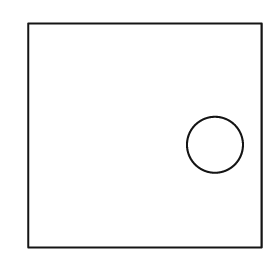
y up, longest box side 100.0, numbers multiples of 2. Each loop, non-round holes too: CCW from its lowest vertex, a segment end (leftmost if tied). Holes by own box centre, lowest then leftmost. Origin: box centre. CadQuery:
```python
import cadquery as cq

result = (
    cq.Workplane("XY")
    .moveTo(-50.0, -48.0)
    .lineTo(50.0, -48.0)
    .lineTo(50.0, 48.0)
    .lineTo(-50.0, 48.0)
    .close()
    .moveTo(30.0, -4.0)
    .circle(12.0)
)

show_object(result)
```